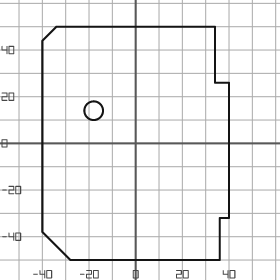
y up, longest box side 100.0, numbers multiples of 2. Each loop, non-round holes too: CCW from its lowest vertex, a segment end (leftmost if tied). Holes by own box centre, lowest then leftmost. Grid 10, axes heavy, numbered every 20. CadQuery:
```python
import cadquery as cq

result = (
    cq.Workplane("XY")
    .moveTo(-28.0, -50.0)
    .lineTo(36.0, -50.0)
    .lineTo(36.0, -32.0)
    .lineTo(40.0, -32.0)
    .lineTo(40.0, 26.0)
    .lineTo(34.0, 26.0)
    .lineTo(34.0, 50.0)
    .lineTo(-34.0, 50.0)
    .lineTo(-40.0, 44.0)
    .lineTo(-40.0, -38.0)
    .close()
    .moveTo(-18.0, 14.0)
    .circle(4.0)
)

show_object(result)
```